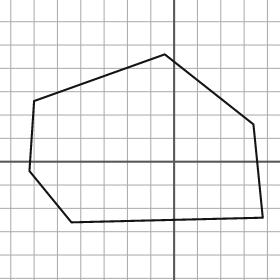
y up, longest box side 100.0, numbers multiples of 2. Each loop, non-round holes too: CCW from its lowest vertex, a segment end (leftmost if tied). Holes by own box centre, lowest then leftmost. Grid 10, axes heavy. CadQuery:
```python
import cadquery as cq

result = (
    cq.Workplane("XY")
    .moveTo(-44.0, -26.0)
    .lineTo(38.0, -24.0)
    .lineTo(34.0, 16.0)
    .lineTo(-4.0, 46.0)
    .lineTo(-60.0, 26.0)
    .lineTo(-62.0, -4.0)
    .close()
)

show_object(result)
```